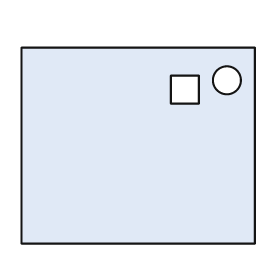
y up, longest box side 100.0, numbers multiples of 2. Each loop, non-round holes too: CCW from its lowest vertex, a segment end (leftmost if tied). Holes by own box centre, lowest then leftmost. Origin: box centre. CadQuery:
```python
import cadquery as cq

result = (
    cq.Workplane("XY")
    .moveTo(-50.0, -42.0)
    .lineTo(50.0, -42.0)
    .lineTo(50.0, 42.0)
    .lineTo(-50.0, 42.0)
    .close()
    .moveTo(14.0, 18.0)
    .lineTo(26.0, 18.0)
    .lineTo(26.0, 30.0)
    .lineTo(14.0, 30.0)
    .close()
    .moveTo(38.0, 28.0)
    .circle(6.0)
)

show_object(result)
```